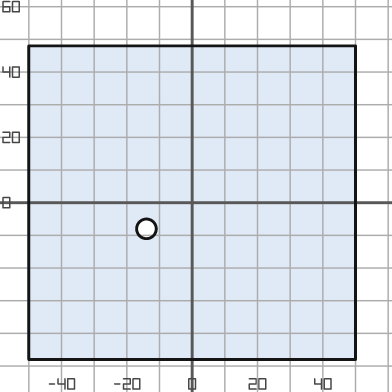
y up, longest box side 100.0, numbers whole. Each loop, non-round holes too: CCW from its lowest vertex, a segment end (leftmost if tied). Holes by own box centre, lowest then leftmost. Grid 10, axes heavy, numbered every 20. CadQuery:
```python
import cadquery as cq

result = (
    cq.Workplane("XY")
    .moveTo(-50.0, -48.0)
    .lineTo(50.0, -48.0)
    .lineTo(50.0, 48.0)
    .lineTo(-50.0, 48.0)
    .close()
    .moveTo(-14.0, -8.0)
    .circle(3.0)
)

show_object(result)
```